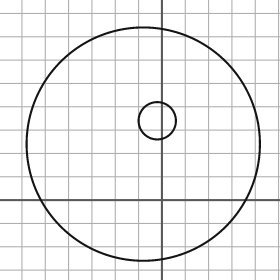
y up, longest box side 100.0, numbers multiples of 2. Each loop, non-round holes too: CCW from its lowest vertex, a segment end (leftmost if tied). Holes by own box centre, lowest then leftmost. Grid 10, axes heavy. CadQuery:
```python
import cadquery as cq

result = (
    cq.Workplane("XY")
    .moveTo(-8.0, 24.0)
    .circle(50.0)
    .moveTo(-2.0, 34.0)
    .circle(8.0)
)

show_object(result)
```